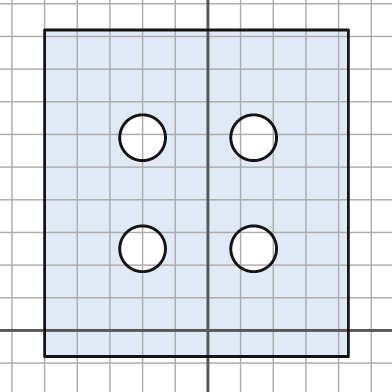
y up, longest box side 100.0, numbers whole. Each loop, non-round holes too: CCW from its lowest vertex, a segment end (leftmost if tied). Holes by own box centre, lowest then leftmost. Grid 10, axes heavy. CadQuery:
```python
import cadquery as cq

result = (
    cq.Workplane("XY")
    .moveTo(-50.0, -8.0)
    .lineTo(43.0, -8.0)
    .lineTo(43.0, 92.0)
    .lineTo(-50.0, 92.0)
    .close()
    .moveTo(-20.0, 25.0)
    .circle(7.0)
    .moveTo(14.0, 25.0)
    .circle(7.0)
    .moveTo(-20.0, 59.0)
    .circle(7.0)
    .moveTo(14.0, 59.0)
    .circle(7.0)
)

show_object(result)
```